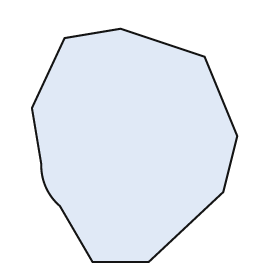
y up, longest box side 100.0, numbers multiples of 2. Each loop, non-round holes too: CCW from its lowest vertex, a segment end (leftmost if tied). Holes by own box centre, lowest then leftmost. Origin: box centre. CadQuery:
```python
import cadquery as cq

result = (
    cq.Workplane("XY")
    .moveTo(-18.0, -50.0)
    .lineTo(6.0, -50.0)
    .lineTo(38.0, -20.0)
    .lineTo(44.0, 4.0)
    .lineTo(30.0, 38.0)
    .lineTo(-6.0, 50.0)
    .lineTo(-30.0, 46.0)
    .lineTo(-44.0, 16.0)
    .lineTo(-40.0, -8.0)
    .threePointArc((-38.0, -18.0), (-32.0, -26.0))
    .close()
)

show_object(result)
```